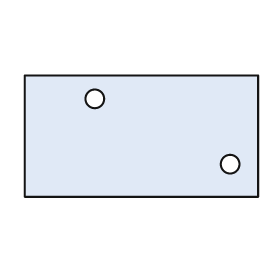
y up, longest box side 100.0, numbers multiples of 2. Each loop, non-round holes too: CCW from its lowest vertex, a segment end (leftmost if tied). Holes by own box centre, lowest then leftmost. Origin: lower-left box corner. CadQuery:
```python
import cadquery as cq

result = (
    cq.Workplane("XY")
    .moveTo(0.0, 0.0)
    .lineTo(100.0, 0.0)
    .lineTo(100.0, 52.0)
    .lineTo(0.0, 52.0)
    .close()
    .moveTo(88.0, 14.0)
    .circle(4.0)
    .moveTo(30.0, 42.0)
    .circle(4.0)
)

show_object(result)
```